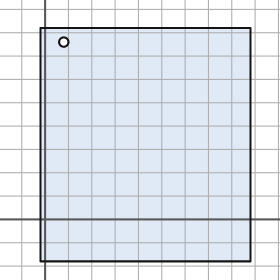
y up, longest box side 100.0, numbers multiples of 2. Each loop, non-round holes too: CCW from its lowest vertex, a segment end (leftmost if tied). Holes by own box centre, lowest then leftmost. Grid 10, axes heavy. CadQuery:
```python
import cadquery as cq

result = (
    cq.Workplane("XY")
    .moveTo(-2.0, -18.0)
    .lineTo(88.0, -18.0)
    .lineTo(88.0, 82.0)
    .lineTo(-2.0, 82.0)
    .close()
    .moveTo(8.0, 76.0)
    .circle(2.0)
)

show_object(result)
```